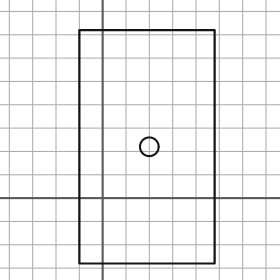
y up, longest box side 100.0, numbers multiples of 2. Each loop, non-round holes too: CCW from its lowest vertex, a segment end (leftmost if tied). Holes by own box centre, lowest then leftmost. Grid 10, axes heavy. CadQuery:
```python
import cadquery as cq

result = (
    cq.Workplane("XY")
    .moveTo(-10.0, -28.0)
    .lineTo(48.0, -28.0)
    .lineTo(48.0, 72.0)
    .lineTo(-10.0, 72.0)
    .close()
    .moveTo(20.0, 22.0)
    .circle(4.0)
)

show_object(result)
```